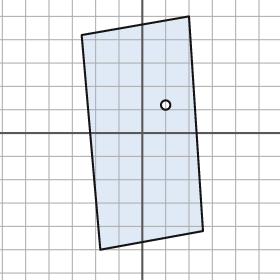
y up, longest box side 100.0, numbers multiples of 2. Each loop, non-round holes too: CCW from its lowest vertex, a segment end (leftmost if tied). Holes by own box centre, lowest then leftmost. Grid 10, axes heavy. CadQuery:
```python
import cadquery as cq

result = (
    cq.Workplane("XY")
    .moveTo(-18.0, -50.0)
    .lineTo(26.0, -42.0)
    .lineTo(20.0, 50.0)
    .lineTo(-26.0, 42.0)
    .close()
    .moveTo(10.0, 12.0)
    .circle(2.0)
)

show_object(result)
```